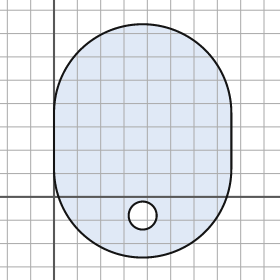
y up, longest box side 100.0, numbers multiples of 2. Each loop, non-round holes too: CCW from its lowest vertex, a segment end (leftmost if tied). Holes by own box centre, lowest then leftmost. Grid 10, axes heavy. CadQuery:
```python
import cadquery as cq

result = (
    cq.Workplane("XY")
    .moveTo(0.0, 12.0)
    .threePointArc((38.0, -26.0), (76.0, 12.0))
    .lineTo(76.0, 36.0)
    .threePointArc((38.0, 74.0), (0.0, 36.0))
    .close()
    .moveTo(38.0, -8.0)
    .circle(6.0)
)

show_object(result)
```